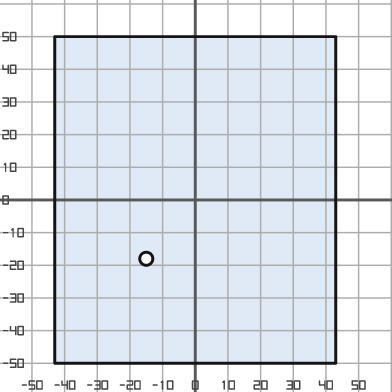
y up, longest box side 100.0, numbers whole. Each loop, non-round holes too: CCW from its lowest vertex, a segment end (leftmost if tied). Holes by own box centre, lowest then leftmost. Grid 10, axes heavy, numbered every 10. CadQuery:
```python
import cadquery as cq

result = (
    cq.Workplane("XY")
    .moveTo(-43.0, -50.0)
    .lineTo(43.0, -50.0)
    .lineTo(43.0, 50.0)
    .lineTo(-43.0, 50.0)
    .close()
    .moveTo(-15.0, -18.0)
    .circle(2.0)
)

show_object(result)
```